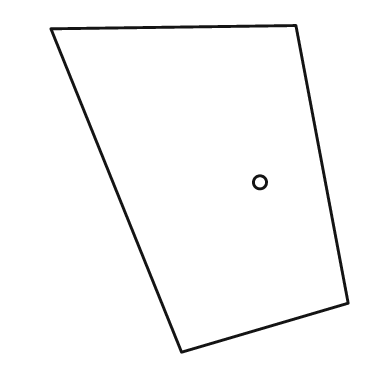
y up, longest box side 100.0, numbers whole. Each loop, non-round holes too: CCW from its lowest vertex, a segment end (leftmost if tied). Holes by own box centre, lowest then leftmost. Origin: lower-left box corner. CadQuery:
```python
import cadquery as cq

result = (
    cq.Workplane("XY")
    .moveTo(40.0, 0.0)
    .lineTo(91.0, 15.0)
    .lineTo(75.0, 100.0)
    .lineTo(0.0, 99.0)
    .close()
    .moveTo(64.0, 52.0)
    .circle(2.0)
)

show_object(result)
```